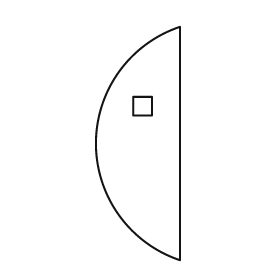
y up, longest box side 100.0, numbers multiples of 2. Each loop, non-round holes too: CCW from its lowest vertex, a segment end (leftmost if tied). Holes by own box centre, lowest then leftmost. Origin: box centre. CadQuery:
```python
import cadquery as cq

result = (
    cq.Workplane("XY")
    .moveTo(18.0, -50.0)
    .lineTo(18.0, 50.0)
    .threePointArc((-18.0, 0.0), (18.0, -50.0))
    .close()
    .moveTo(-2.0, 12.0)
    .lineTo(6.0, 12.0)
    .lineTo(6.0, 20.0)
    .lineTo(-2.0, 20.0)
    .close()
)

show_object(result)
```